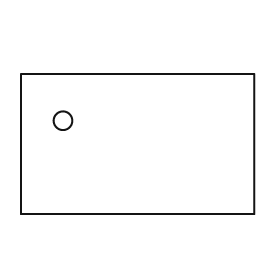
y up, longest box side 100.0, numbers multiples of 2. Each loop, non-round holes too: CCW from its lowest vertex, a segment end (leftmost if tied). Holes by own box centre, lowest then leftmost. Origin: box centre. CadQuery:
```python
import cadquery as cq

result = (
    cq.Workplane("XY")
    .moveTo(-50.0, -30.0)
    .lineTo(50.0, -30.0)
    .lineTo(50.0, 30.0)
    .lineTo(-50.0, 30.0)
    .close()
    .moveTo(-32.0, 10.0)
    .circle(4.0)
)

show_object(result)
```